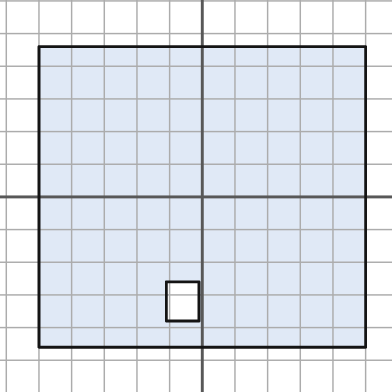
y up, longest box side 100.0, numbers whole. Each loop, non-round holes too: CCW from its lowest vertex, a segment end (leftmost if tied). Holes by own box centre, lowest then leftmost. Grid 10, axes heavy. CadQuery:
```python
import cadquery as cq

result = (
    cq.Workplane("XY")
    .moveTo(-50.0, -46.0)
    .lineTo(50.0, -46.0)
    .lineTo(50.0, 46.0)
    .lineTo(-50.0, 46.0)
    .close()
    .moveTo(-11.0, -38.0)
    .lineTo(-1.0, -38.0)
    .lineTo(-1.0, -26.0)
    .lineTo(-11.0, -26.0)
    .close()
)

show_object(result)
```